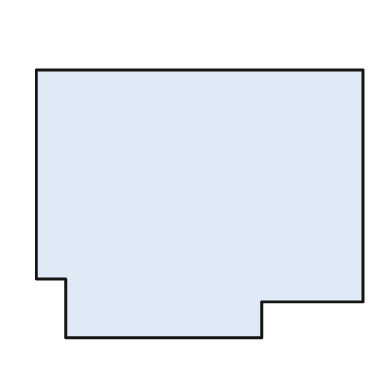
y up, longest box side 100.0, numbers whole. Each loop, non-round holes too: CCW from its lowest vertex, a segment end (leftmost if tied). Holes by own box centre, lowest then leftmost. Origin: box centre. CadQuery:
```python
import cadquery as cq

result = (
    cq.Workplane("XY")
    .moveTo(-41.0, -41.0)
    .lineTo(19.0, -41.0)
    .lineTo(19.0, -30.0)
    .lineTo(50.0, -30.0)
    .lineTo(50.0, 41.0)
    .lineTo(-50.0, 41.0)
    .lineTo(-50.0, -23.0)
    .lineTo(-41.0, -23.0)
    .close()
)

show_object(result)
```